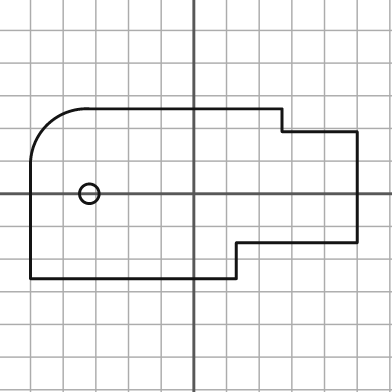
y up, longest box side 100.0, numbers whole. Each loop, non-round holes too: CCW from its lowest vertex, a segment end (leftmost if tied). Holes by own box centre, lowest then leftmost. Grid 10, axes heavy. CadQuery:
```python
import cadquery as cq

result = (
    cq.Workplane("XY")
    .moveTo(-50.0, -26.0)
    .lineTo(13.0, -26.0)
    .lineTo(13.0, -15.0)
    .lineTo(50.0, -15.0)
    .lineTo(50.0, 19.0)
    .lineTo(27.0, 19.0)
    .lineTo(27.0, 26.0)
    .lineTo(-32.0, 26.0)
    .threePointArc((-45.0, 21.0), (-50.0, 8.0))
    .close()
    .moveTo(-32.0, 0.0)
    .circle(3.0)
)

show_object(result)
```